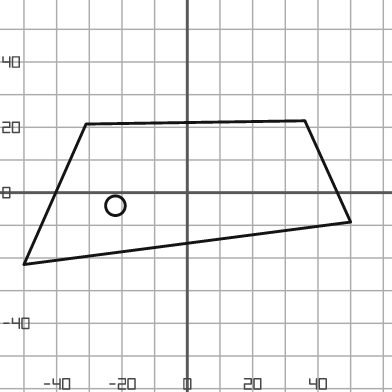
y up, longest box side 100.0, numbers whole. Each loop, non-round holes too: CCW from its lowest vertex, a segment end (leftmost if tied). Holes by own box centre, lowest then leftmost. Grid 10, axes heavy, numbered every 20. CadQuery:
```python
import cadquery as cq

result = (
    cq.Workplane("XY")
    .moveTo(-50.0, -22.0)
    .lineTo(50.0, -9.0)
    .lineTo(36.0, 22.0)
    .lineTo(-31.0, 21.0)
    .close()
    .moveTo(-22.0, -4.0)
    .circle(3.0)
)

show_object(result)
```